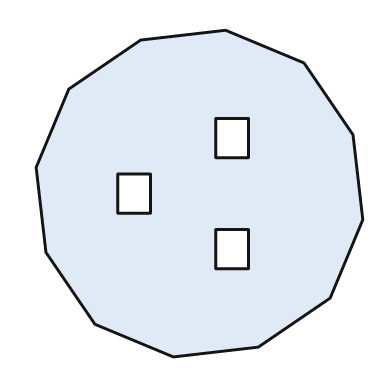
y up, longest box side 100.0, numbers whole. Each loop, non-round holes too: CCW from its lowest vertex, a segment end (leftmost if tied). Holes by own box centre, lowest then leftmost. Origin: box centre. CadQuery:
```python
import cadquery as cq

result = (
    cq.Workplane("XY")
    .moveTo(-8.0, -50.0)
    .lineTo(18.0, -47.0)
    .lineTo(40.0, -32.0)
    .lineTo(50.0, -8.0)
    .lineTo(47.0, 18.0)
    .lineTo(32.0, 40.0)
    .lineTo(8.0, 50.0)
    .lineTo(-18.0, 47.0)
    .lineTo(-40.0, 32.0)
    .lineTo(-50.0, 8.0)
    .lineTo(-47.0, -18.0)
    .lineTo(-32.0, -40.0)
    .close()
    .moveTo(5.0, -23.0)
    .lineTo(15.0, -23.0)
    .lineTo(15.0, -11.0)
    .lineTo(5.0, -11.0)
    .close()
    .moveTo(-25.0, -6.0)
    .lineTo(-15.0, -6.0)
    .lineTo(-15.0, 6.0)
    .lineTo(-25.0, 6.0)
    .close()
    .moveTo(5.0, 11.0)
    .lineTo(15.0, 11.0)
    .lineTo(15.0, 23.0)
    .lineTo(5.0, 23.0)
    .close()
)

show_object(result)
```